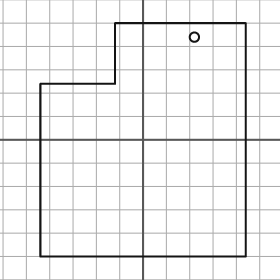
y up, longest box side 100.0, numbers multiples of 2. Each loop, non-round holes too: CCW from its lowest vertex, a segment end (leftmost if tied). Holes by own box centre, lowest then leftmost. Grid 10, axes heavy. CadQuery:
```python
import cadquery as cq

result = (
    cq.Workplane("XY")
    .moveTo(-44.0, -50.0)
    .lineTo(44.0, -50.0)
    .lineTo(44.0, 50.0)
    .lineTo(-12.0, 50.0)
    .lineTo(-12.0, 24.0)
    .lineTo(-44.0, 24.0)
    .close()
    .moveTo(22.0, 44.0)
    .circle(2.0)
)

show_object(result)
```